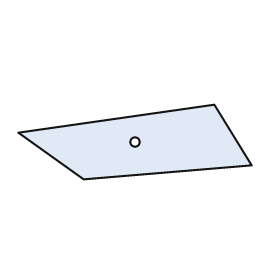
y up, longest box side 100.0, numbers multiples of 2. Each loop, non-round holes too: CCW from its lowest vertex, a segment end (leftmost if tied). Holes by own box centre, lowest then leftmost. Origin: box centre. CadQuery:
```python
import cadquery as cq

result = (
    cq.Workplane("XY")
    .moveTo(-22.0, -16.0)
    .lineTo(50.0, -10.0)
    .lineTo(34.0, 16.0)
    .lineTo(-50.0, 4.0)
    .close()
    .moveTo(0.0, 0.0)
    .circle(2.0)
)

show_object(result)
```